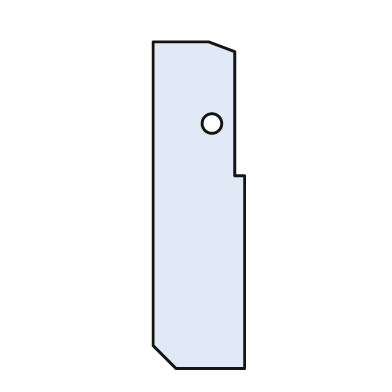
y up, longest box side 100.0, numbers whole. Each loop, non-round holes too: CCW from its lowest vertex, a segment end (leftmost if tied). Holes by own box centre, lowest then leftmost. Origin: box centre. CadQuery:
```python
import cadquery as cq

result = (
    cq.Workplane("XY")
    .moveTo(-7.0, -50.0)
    .lineTo(14.0, -50.0)
    .lineTo(14.0, 9.0)
    .lineTo(11.0, 9.0)
    .lineTo(11.0, 47.0)
    .lineTo(3.0, 50.0)
    .lineTo(-14.0, 50.0)
    .lineTo(-14.0, -43.0)
    .close()
    .moveTo(4.0, 25.0)
    .circle(3.0)
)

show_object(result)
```